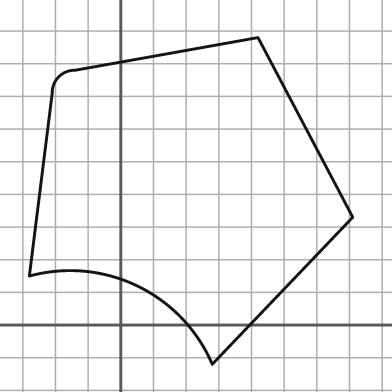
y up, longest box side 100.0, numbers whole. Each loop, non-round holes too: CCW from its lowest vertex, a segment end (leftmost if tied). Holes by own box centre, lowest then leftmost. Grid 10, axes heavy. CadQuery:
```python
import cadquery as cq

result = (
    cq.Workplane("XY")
    .moveTo(28.0, -12.0)
    .lineTo(71.0, 33.0)
    .lineTo(42.0, 88.0)
    .lineTo(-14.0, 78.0)
    .threePointArc((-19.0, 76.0), (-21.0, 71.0))
    .lineTo(-28.0, 15.0)
    .threePointArc((5.0, 12.0), (28.0, -12.0))
    .close()
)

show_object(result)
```